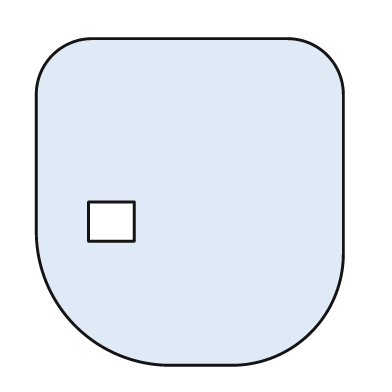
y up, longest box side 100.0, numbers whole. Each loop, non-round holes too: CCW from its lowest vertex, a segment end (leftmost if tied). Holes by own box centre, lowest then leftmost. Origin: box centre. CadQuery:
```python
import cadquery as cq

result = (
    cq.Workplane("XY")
    .moveTo(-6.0, -50.0)
    .lineTo(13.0, -50.0)
    .threePointArc((37.0, -40.0), (47.0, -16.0))
    .lineTo(47.0, 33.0)
    .threePointArc((42.0, 45.0), (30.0, 50.0))
    .lineTo(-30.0, 50.0)
    .threePointArc((-42.0, 45.0), (-47.0, 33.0))
    .lineTo(-47.0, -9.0)
    .threePointArc((-35.0, -38.0), (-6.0, -50.0))
    .close()
    .moveTo(-31.0, -12.0)
    .lineTo(-17.0, -12.0)
    .lineTo(-17.0, 0.0)
    .lineTo(-31.0, 0.0)
    .close()
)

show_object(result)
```